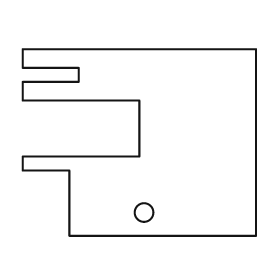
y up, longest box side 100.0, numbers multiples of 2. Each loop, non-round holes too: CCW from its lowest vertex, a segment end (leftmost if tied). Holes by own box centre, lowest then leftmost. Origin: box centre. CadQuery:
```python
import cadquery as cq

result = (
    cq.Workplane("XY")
    .moveTo(-30.0, -40.0)
    .lineTo(50.0, -40.0)
    .lineTo(50.0, 40.0)
    .lineTo(-50.0, 40.0)
    .lineTo(-50.0, 32.0)
    .lineTo(-26.0, 32.0)
    .lineTo(-26.0, 26.0)
    .lineTo(-50.0, 26.0)
    .lineTo(-50.0, 18.0)
    .lineTo(0.0, 18.0)
    .lineTo(0.0, -6.0)
    .lineTo(-50.0, -6.0)
    .lineTo(-50.0, -12.0)
    .lineTo(-30.0, -12.0)
    .close()
    .moveTo(2.0, -30.0)
    .circle(4.0)
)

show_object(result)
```